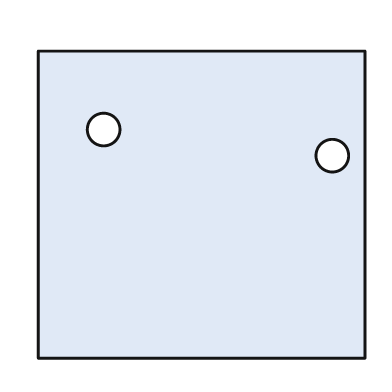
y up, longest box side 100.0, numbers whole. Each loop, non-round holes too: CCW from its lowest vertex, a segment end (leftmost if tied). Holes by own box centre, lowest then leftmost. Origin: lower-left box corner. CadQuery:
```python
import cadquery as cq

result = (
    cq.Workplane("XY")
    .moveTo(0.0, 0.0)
    .lineTo(100.0, 0.0)
    .lineTo(100.0, 94.0)
    .lineTo(0.0, 94.0)
    .close()
    .moveTo(90.0, 62.0)
    .circle(5.0)
    .moveTo(20.0, 70.0)
    .circle(5.0)
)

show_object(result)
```